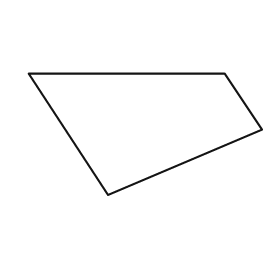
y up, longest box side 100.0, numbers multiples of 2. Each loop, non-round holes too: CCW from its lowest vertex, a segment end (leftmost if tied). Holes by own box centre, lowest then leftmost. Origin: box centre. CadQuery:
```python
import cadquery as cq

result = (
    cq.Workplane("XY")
    .moveTo(-16.0, -26.0)
    .lineTo(50.0, 2.0)
    .lineTo(34.0, 26.0)
    .lineTo(-50.0, 26.0)
    .close()
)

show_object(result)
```